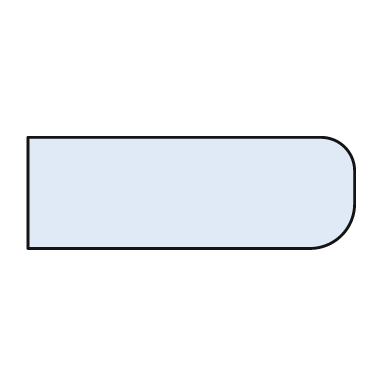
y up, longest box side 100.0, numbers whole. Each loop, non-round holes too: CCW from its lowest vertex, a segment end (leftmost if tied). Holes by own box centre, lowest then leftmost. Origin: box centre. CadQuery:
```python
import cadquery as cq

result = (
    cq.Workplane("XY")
    .moveTo(-50.0, -17.0)
    .lineTo(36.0, -17.0)
    .threePointArc((46.0, -13.0), (50.0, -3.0))
    .lineTo(50.0, 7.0)
    .threePointArc((47.0, 14.0), (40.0, 17.0))
    .lineTo(-50.0, 17.0)
    .close()
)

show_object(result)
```